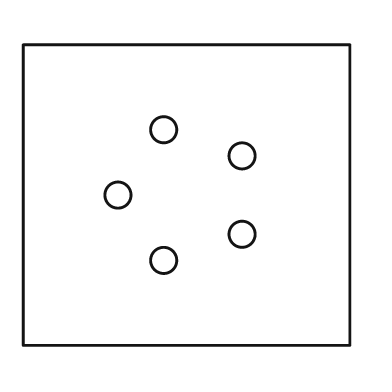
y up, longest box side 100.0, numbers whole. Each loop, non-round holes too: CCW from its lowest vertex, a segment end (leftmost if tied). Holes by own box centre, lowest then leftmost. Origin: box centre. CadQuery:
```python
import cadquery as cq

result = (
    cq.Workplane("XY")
    .moveTo(-50.0, -46.0)
    .lineTo(50.0, -46.0)
    .lineTo(50.0, 46.0)
    .lineTo(-50.0, 46.0)
    .close()
    .moveTo(-7.0, -20.0)
    .circle(4.0)
    .moveTo(17.0, -12.0)
    .circle(4.0)
    .moveTo(-21.0, 0.0)
    .circle(4.0)
    .moveTo(17.0, 12.0)
    .circle(4.0)
    .moveTo(-7.0, 20.0)
    .circle(4.0)
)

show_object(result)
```